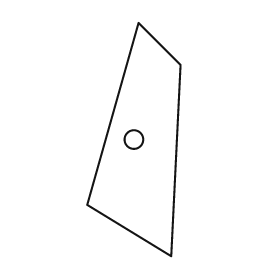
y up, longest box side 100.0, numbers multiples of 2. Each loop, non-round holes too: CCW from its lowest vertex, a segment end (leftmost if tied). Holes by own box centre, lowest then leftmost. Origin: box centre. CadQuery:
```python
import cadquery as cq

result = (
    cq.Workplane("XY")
    .moveTo(16.0, -50.0)
    .lineTo(20.0, 32.0)
    .lineTo(2.0, 50.0)
    .lineTo(-20.0, -28.0)
    .close()
    .moveTo(0.0, 0.0)
    .circle(4.0)
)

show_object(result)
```